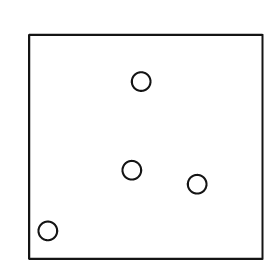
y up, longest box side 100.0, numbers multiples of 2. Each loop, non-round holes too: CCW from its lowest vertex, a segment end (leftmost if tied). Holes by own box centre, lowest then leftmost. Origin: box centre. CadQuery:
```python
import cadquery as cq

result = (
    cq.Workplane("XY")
    .moveTo(-50.0, -48.0)
    .lineTo(50.0, -48.0)
    .lineTo(50.0, 48.0)
    .lineTo(-50.0, 48.0)
    .close()
    .moveTo(-42.0, -36.0)
    .circle(4.0)
    .moveTo(22.0, -16.0)
    .circle(4.0)
    .moveTo(-6.0, -10.0)
    .circle(4.0)
    .moveTo(-2.0, 28.0)
    .circle(4.0)
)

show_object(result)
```